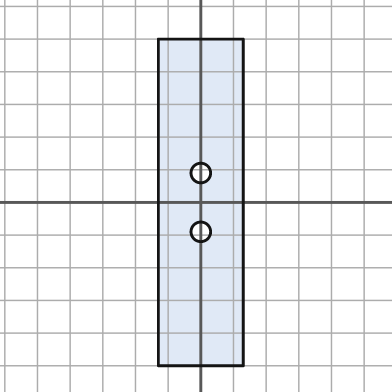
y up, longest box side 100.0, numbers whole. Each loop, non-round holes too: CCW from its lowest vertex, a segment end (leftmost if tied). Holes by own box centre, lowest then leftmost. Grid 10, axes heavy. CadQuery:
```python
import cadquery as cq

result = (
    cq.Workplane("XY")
    .moveTo(-13.0, -50.0)
    .lineTo(13.0, -50.0)
    .lineTo(13.0, 50.0)
    .lineTo(-13.0, 50.0)
    .close()
    .moveTo(0.0, -9.0)
    .circle(3.0)
    .moveTo(0.0, 9.0)
    .circle(3.0)
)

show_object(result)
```